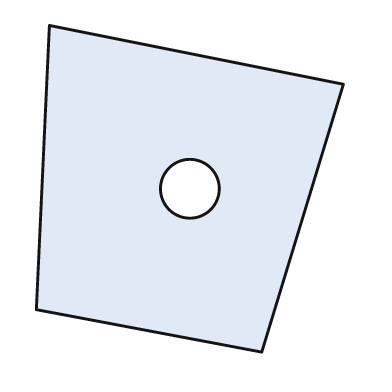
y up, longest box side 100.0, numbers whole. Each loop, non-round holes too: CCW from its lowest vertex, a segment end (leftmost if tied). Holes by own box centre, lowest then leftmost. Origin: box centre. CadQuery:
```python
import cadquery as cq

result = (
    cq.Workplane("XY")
    .moveTo(22.0, -50.0)
    .lineTo(47.0, 32.0)
    .lineTo(-43.0, 50.0)
    .lineTo(-47.0, -37.0)
    .close()
    .moveTo(0.0, 0.0)
    .circle(9.0)
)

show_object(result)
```